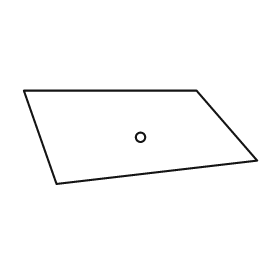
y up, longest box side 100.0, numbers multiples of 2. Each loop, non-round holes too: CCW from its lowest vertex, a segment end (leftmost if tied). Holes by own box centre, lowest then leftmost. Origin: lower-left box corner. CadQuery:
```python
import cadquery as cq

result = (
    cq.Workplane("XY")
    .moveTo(14.0, 0.0)
    .lineTo(100.0, 10.0)
    .lineTo(74.0, 40.0)
    .lineTo(0.0, 40.0)
    .close()
    .moveTo(50.0, 20.0)
    .circle(2.0)
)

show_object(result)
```